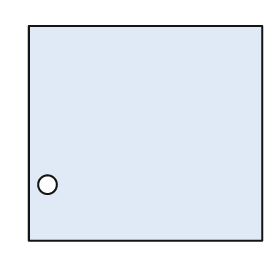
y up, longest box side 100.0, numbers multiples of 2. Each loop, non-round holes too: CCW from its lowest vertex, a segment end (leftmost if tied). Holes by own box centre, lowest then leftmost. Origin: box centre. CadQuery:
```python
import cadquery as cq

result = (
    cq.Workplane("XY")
    .moveTo(-50.0, -46.0)
    .lineTo(50.0, -46.0)
    .lineTo(50.0, 46.0)
    .lineTo(-50.0, 46.0)
    .close()
    .moveTo(-42.0, -22.0)
    .circle(4.0)
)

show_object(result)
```